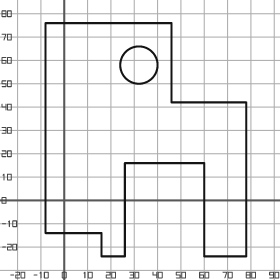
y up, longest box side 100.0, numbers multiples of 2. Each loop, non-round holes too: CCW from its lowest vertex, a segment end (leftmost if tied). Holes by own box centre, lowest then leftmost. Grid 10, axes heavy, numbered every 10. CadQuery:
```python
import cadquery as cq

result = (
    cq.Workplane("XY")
    .moveTo(16.0, -24.0)
    .lineTo(26.0, -24.0)
    .lineTo(26.0, 16.0)
    .lineTo(60.0, 16.0)
    .lineTo(60.0, -24.0)
    .lineTo(78.0, -24.0)
    .lineTo(78.0, 42.0)
    .lineTo(46.0, 42.0)
    .lineTo(46.0, 76.0)
    .lineTo(-8.0, 76.0)
    .lineTo(-8.0, -14.0)
    .lineTo(16.0, -14.0)
    .close()
    .moveTo(32.0, 58.0)
    .circle(8.0)
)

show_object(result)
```